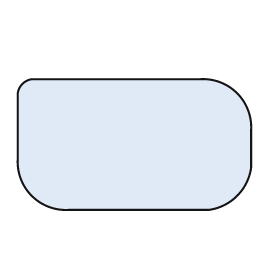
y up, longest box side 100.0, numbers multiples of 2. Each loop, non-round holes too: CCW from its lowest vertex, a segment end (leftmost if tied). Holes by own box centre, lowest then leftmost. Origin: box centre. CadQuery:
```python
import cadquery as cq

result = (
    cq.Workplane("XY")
    .moveTo(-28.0, -28.0)
    .lineTo(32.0, -28.0)
    .threePointArc((44.0, -22.0), (50.0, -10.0))
    .lineTo(50.0, 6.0)
    .threePointArc((44.0, 22.0), (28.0, 28.0))
    .lineTo(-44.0, 28.0)
    .threePointArc((-48.0, 26.0), (-50.0, 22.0))
    .lineTo(-50.0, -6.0)
    .threePointArc((-44.0, -22.0), (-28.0, -28.0))
    .close()
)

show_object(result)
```